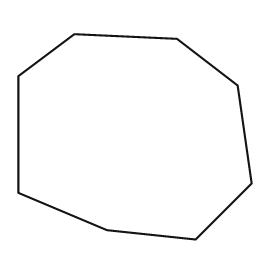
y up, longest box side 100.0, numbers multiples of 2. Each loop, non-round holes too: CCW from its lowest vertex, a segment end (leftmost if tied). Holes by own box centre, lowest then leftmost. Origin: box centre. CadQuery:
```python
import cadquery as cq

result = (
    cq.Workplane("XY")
    .moveTo(26.0, -44.0)
    .lineTo(50.0, -20.0)
    .lineTo(44.0, 22.0)
    .lineTo(18.0, 42.0)
    .lineTo(-26.0, 44.0)
    .lineTo(-50.0, 26.0)
    .lineTo(-50.0, -24.0)
    .lineTo(-12.0, -40.0)
    .close()
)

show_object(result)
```